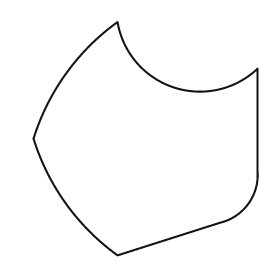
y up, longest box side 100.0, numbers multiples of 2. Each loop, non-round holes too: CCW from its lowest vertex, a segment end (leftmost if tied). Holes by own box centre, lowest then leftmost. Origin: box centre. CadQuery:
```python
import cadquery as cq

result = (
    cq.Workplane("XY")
    .moveTo(-12.0, -50.0)
    .lineTo(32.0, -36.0)
    .threePointArc((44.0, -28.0), (48.0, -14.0))
    .lineTo(48.0, 30.0)
    .threePointArc((12.0, 22.0), (-12.0, 50.0))
    .threePointArc((-34.0, 28.0), (-48.0, 0.0))
    .threePointArc((-34.0, -28.0), (-12.0, -50.0))
    .close()
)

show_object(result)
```